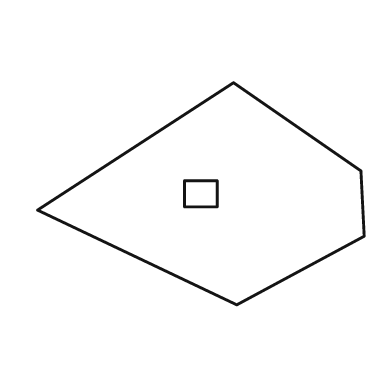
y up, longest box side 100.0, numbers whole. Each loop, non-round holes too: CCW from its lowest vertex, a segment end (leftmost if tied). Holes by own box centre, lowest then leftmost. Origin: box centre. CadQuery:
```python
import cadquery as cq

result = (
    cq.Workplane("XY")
    .moveTo(11.0, -34.0)
    .lineTo(50.0, -13.0)
    .lineTo(49.0, 7.0)
    .lineTo(10.0, 34.0)
    .lineTo(-50.0, -5.0)
    .close()
    .moveTo(-5.0, -4.0)
    .lineTo(5.0, -4.0)
    .lineTo(5.0, 4.0)
    .lineTo(-5.0, 4.0)
    .close()
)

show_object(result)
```